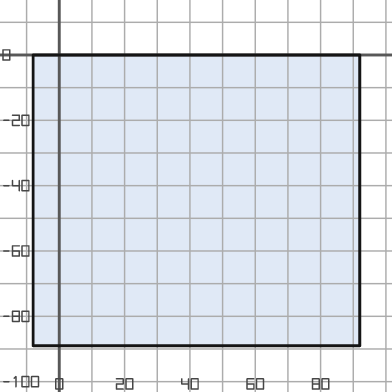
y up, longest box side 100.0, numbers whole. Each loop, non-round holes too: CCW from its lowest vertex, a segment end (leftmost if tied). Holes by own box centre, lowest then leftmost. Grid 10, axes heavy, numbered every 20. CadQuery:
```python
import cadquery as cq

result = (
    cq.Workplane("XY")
    .moveTo(-8.0, -89.0)
    .lineTo(92.0, -89.0)
    .lineTo(92.0, 0.0)
    .lineTo(-8.0, 0.0)
    .close()
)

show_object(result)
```